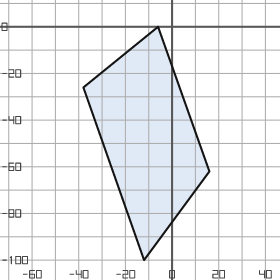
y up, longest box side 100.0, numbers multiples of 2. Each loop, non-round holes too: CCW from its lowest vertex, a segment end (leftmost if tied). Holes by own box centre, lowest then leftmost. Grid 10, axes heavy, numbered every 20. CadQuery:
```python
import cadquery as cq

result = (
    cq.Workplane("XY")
    .moveTo(-12.0, -100.0)
    .lineTo(16.0, -62.0)
    .lineTo(-6.0, 0.0)
    .lineTo(-38.0, -26.0)
    .close()
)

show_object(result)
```